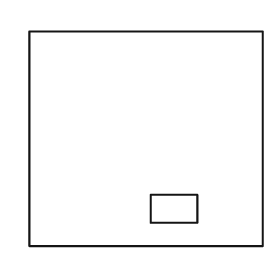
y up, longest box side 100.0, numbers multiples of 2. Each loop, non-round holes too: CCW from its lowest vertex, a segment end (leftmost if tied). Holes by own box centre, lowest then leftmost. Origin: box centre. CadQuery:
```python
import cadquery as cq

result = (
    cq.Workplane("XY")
    .moveTo(-50.0, -46.0)
    .lineTo(50.0, -46.0)
    .lineTo(50.0, 46.0)
    .lineTo(-50.0, 46.0)
    .close()
    .moveTo(2.0, -36.0)
    .lineTo(22.0, -36.0)
    .lineTo(22.0, -24.0)
    .lineTo(2.0, -24.0)
    .close()
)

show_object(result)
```